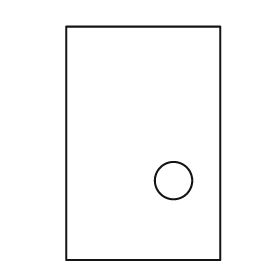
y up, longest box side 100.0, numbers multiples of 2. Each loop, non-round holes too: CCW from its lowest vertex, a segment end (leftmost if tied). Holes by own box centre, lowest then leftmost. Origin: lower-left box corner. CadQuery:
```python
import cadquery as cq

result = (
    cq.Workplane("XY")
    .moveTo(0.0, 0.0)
    .lineTo(66.0, 0.0)
    .lineTo(66.0, 100.0)
    .lineTo(0.0, 100.0)
    .close()
    .moveTo(46.0, 34.0)
    .circle(8.0)
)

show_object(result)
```